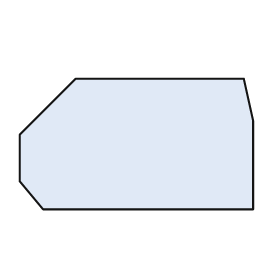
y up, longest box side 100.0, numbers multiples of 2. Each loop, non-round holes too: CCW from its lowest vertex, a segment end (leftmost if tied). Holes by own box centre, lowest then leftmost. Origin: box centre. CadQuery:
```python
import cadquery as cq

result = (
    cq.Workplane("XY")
    .moveTo(-40.0, -28.0)
    .lineTo(50.0, -28.0)
    .lineTo(50.0, 10.0)
    .lineTo(46.0, 28.0)
    .lineTo(-26.0, 28.0)
    .lineTo(-50.0, 4.0)
    .lineTo(-50.0, -16.0)
    .close()
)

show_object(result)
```